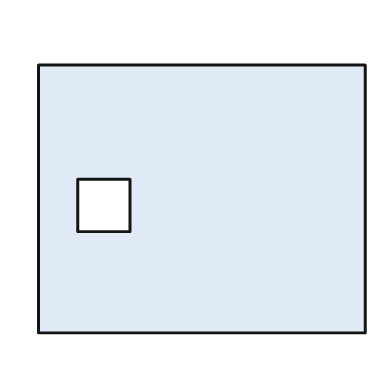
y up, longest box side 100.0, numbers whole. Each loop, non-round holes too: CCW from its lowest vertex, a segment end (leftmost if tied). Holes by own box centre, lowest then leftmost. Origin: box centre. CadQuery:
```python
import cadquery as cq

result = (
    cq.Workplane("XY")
    .moveTo(-50.0, -41.0)
    .lineTo(50.0, -41.0)
    .lineTo(50.0, 41.0)
    .lineTo(-50.0, 41.0)
    .close()
    .moveTo(-38.0, -10.0)
    .lineTo(-22.0, -10.0)
    .lineTo(-22.0, 6.0)
    .lineTo(-38.0, 6.0)
    .close()
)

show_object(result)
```